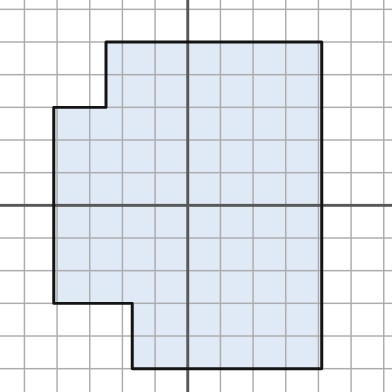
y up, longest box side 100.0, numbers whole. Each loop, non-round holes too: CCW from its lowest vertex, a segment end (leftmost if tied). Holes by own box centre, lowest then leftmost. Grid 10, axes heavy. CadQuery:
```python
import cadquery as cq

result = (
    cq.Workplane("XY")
    .moveTo(-17.0, -50.0)
    .lineTo(41.0, -50.0)
    .lineTo(41.0, 50.0)
    .lineTo(-25.0, 50.0)
    .lineTo(-25.0, 30.0)
    .lineTo(-41.0, 30.0)
    .lineTo(-41.0, -30.0)
    .lineTo(-17.0, -30.0)
    .close()
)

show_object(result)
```